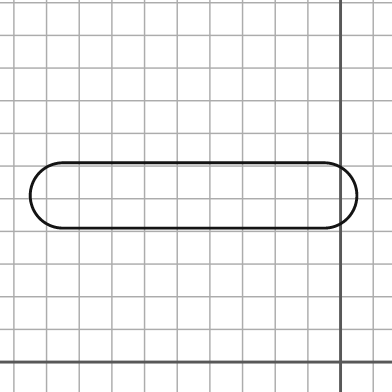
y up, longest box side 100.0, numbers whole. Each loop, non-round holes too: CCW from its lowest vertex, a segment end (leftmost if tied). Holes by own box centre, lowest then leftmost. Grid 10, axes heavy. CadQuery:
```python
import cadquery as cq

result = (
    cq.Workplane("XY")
    .moveTo(-85.0, 41.0)
    .lineTo(-5.0, 41.0)
    .threePointArc((5.0, 51.0), (-5.0, 61.0))
    .lineTo(-85.0, 61.0)
    .threePointArc((-95.0, 51.0), (-85.0, 41.0))
    .close()
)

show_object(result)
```